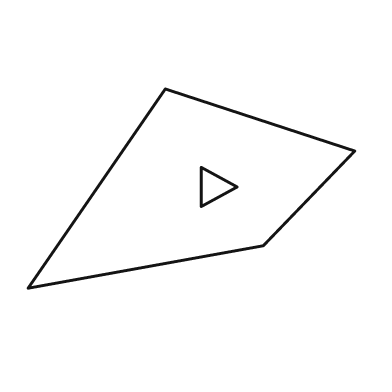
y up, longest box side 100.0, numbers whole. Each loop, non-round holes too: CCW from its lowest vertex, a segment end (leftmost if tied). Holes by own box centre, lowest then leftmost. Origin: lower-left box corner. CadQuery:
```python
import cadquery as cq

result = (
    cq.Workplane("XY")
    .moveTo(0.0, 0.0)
    .lineTo(72.0, 13.0)
    .lineTo(100.0, 42.0)
    .lineTo(42.0, 61.0)
    .close()
    .moveTo(53.0, 25.0)
    .lineTo(64.0, 31.0)
    .lineTo(53.0, 37.0)
    .close()
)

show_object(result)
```